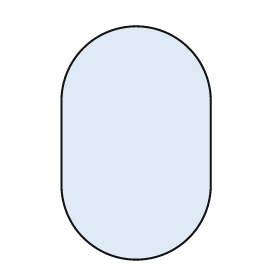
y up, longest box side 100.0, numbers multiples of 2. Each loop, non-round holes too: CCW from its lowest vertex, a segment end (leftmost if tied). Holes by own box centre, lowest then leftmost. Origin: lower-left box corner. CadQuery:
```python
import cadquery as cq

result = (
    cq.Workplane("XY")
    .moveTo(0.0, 32.0)
    .threePointArc((32.0, 0.0), (64.0, 32.0))
    .lineTo(64.0, 68.0)
    .threePointArc((32.0, 100.0), (0.0, 68.0))
    .close()
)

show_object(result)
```